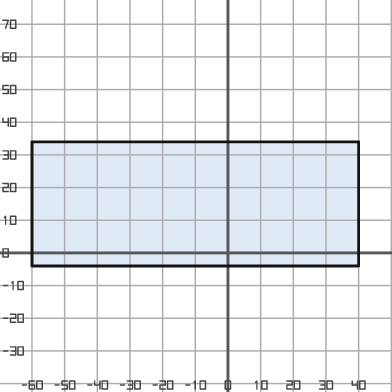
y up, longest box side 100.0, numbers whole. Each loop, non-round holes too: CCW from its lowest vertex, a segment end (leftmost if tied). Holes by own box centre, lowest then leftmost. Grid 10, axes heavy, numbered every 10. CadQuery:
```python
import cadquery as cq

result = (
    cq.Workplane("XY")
    .moveTo(-60.0, -4.0)
    .lineTo(40.0, -4.0)
    .lineTo(40.0, 34.0)
    .lineTo(-60.0, 34.0)
    .close()
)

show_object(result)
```